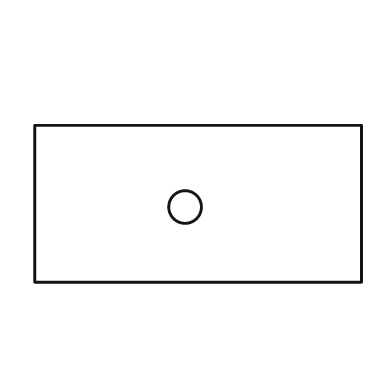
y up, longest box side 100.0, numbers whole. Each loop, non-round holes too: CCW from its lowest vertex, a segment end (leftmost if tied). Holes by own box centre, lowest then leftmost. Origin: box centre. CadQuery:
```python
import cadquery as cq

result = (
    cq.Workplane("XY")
    .moveTo(-50.0, -24.0)
    .lineTo(50.0, -24.0)
    .lineTo(50.0, 24.0)
    .lineTo(-50.0, 24.0)
    .close()
    .moveTo(-4.0, -1.0)
    .circle(5.0)
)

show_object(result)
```